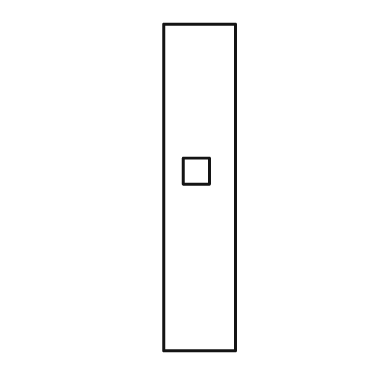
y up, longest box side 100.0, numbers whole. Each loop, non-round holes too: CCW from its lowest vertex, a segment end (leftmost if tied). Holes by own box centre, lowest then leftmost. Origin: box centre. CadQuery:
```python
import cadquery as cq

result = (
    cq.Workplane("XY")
    .moveTo(-11.0, -50.0)
    .lineTo(11.0, -50.0)
    .lineTo(11.0, 50.0)
    .lineTo(-11.0, 50.0)
    .close()
    .moveTo(-5.0, 1.0)
    .lineTo(3.0, 1.0)
    .lineTo(3.0, 9.0)
    .lineTo(-5.0, 9.0)
    .close()
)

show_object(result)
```